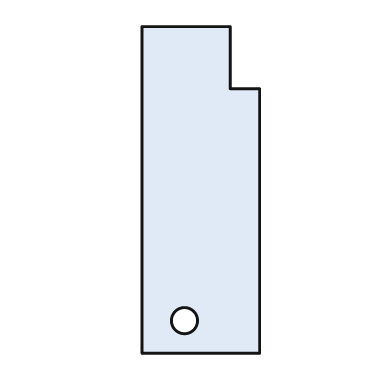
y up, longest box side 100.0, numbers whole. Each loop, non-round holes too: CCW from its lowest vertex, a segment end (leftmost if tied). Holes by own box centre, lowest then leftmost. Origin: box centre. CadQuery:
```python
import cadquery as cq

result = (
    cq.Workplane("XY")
    .moveTo(-18.0, -50.0)
    .lineTo(18.0, -50.0)
    .lineTo(18.0, 31.0)
    .lineTo(9.0, 31.0)
    .lineTo(9.0, 50.0)
    .lineTo(-18.0, 50.0)
    .close()
    .moveTo(-5.0, -40.0)
    .circle(4.0)
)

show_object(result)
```